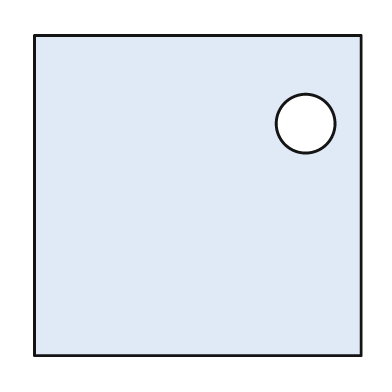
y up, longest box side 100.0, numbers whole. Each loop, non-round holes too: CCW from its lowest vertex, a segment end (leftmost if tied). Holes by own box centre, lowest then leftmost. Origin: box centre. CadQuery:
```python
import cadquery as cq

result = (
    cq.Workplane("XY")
    .moveTo(-50.0, -49.0)
    .lineTo(50.0, -49.0)
    .lineTo(50.0, 49.0)
    .lineTo(-50.0, 49.0)
    .close()
    .moveTo(33.0, 22.0)
    .circle(9.0)
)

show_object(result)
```